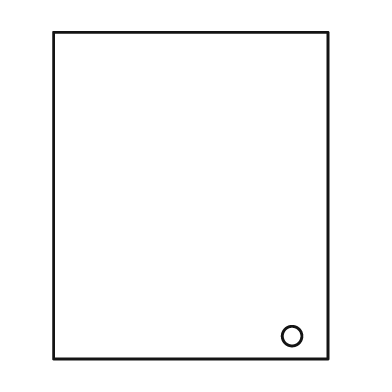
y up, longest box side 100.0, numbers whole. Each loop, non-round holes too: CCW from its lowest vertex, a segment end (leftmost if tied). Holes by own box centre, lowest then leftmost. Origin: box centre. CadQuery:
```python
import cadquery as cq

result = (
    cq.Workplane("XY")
    .moveTo(-42.0, -50.0)
    .lineTo(42.0, -50.0)
    .lineTo(42.0, 50.0)
    .lineTo(-42.0, 50.0)
    .close()
    .moveTo(31.0, -43.0)
    .circle(3.0)
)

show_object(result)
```